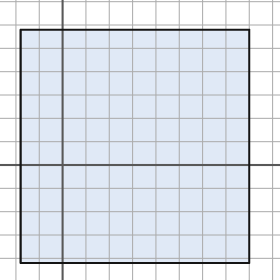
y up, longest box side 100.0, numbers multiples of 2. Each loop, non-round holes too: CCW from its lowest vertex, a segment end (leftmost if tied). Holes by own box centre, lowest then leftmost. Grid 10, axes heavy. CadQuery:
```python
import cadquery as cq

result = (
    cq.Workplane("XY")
    .moveTo(-18.0, -42.0)
    .lineTo(80.0, -42.0)
    .lineTo(80.0, 58.0)
    .lineTo(-18.0, 58.0)
    .close()
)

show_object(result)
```